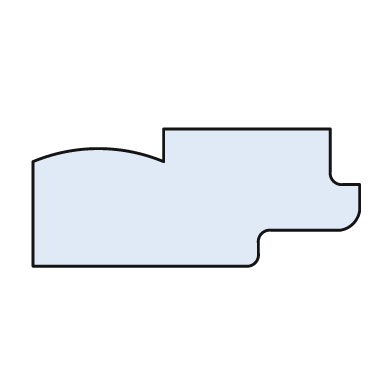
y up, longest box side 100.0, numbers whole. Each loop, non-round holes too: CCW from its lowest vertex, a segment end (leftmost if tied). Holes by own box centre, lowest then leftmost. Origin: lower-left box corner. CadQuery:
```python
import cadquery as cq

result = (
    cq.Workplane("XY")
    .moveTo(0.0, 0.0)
    .lineTo(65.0, 0.0)
    .threePointArc((68.0, 1.0), (69.0, 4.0))
    .lineTo(69.0, 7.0)
    .threePointArc((70.0, 10.0), (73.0, 11.0))
    .lineTo(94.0, 11.0)
    .threePointArc((98.0, 13.0), (100.0, 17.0))
    .lineTo(100.0, 25.0)
    .lineTo(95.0, 25.0)
    .threePointArc((92.0, 26.0), (91.0, 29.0))
    .lineTo(91.0, 42.0)
    .lineTo(40.0, 42.0)
    .lineTo(40.0, 32.0)
    .threePointArc((20.0, 36.0), (0.0, 32.0))
    .close()
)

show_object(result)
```